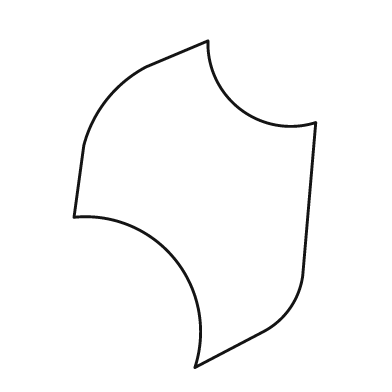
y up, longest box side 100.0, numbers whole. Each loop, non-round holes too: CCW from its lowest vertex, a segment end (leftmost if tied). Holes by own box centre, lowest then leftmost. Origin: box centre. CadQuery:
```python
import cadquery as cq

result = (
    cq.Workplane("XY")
    .moveTo(0.0, -50.0)
    .lineTo(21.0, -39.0)
    .threePointArc((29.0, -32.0), (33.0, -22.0))
    .lineTo(37.0, 25.0)
    .threePointArc((14.0, 29.0), (4.0, 50.0))
    .lineTo(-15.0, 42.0)
    .threePointArc((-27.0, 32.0), (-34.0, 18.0))
    .lineTo(-37.0, -4.0)
    .threePointArc((-6.0, -17.0), (0.0, -50.0))
    .close()
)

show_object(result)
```